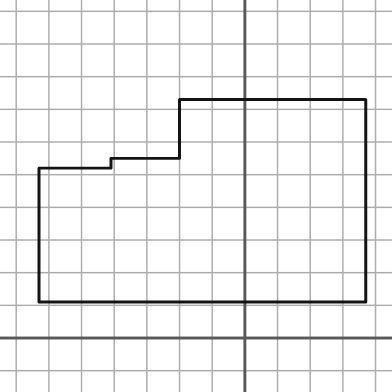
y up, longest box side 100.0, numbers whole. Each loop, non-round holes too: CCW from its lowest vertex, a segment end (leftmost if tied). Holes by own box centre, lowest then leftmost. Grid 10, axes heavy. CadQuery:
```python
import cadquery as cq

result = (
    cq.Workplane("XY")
    .moveTo(-63.0, 11.0)
    .lineTo(37.0, 11.0)
    .lineTo(37.0, 73.0)
    .lineTo(-20.0, 73.0)
    .lineTo(-20.0, 55.0)
    .lineTo(-41.0, 55.0)
    .lineTo(-41.0, 52.0)
    .lineTo(-63.0, 52.0)
    .close()
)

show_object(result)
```